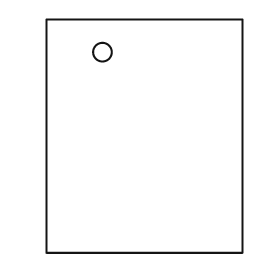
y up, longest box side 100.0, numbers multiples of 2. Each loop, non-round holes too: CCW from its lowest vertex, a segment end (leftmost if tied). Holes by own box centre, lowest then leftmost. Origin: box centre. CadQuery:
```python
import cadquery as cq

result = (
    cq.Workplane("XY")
    .moveTo(-42.0, -50.0)
    .lineTo(42.0, -50.0)
    .lineTo(42.0, 50.0)
    .lineTo(-42.0, 50.0)
    .close()
    .moveTo(-18.0, 36.0)
    .circle(4.0)
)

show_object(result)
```